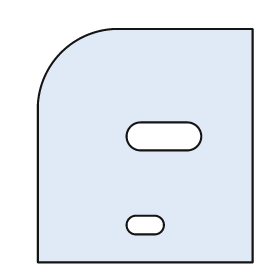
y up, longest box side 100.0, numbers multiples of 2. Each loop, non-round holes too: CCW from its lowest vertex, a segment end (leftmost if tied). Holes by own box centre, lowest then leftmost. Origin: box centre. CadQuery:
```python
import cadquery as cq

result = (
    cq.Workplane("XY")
    .moveTo(-46.0, -50.0)
    .lineTo(46.0, -50.0)
    .lineTo(46.0, 50.0)
    .lineTo(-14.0, 50.0)
    .threePointArc((-36.0, 40.0), (-46.0, 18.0))
    .close()
    .moveTo(-4.0, -38.0)
    .lineTo(4.0, -38.0)
    .threePointArc((8.0, -34.0), (4.0, -30.0))
    .lineTo(-4.0, -30.0)
    .threePointArc((-8.0, -34.0), (-4.0, -38.0))
    .close()
    .moveTo(-2.0, -2.0)
    .lineTo(18.0, -2.0)
    .threePointArc((24.0, 4.0), (18.0, 10.0))
    .lineTo(-2.0, 10.0)
    .threePointArc((-8.0, 4.0), (-2.0, -2.0))
    .close()
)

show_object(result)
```